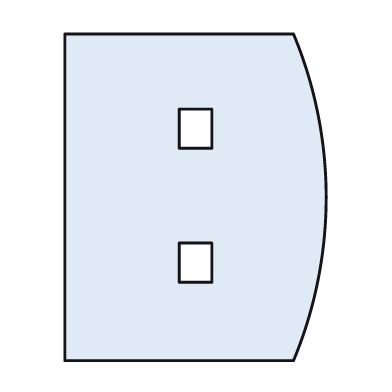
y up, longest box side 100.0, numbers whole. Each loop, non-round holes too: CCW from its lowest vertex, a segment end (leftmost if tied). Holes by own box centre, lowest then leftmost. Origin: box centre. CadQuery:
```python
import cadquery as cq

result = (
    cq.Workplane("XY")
    .moveTo(-40.0, -50.0)
    .lineTo(30.0, -50.0)
    .threePointArc((40.0, 0.0), (30.0, 50.0))
    .lineTo(-40.0, 50.0)
    .close()
    .moveTo(-5.0, -26.0)
    .lineTo(5.0, -26.0)
    .lineTo(5.0, -14.0)
    .lineTo(-5.0, -14.0)
    .close()
    .moveTo(-5.0, 15.0)
    .lineTo(5.0, 15.0)
    .lineTo(5.0, 27.0)
    .lineTo(-5.0, 27.0)
    .close()
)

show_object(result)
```